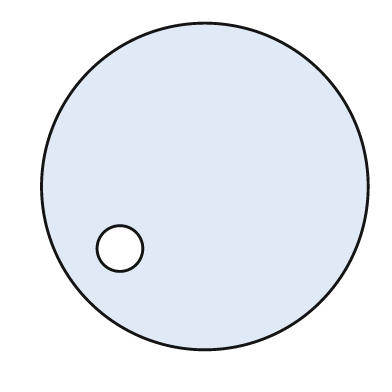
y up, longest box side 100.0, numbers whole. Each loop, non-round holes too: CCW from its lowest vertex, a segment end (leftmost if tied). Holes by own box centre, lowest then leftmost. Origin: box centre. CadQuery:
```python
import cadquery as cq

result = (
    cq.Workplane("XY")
    .moveTo(0.0, 0.0)
    .circle(50.0)
    .moveTo(-26.0, -19.0)
    .circle(7.0)
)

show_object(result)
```